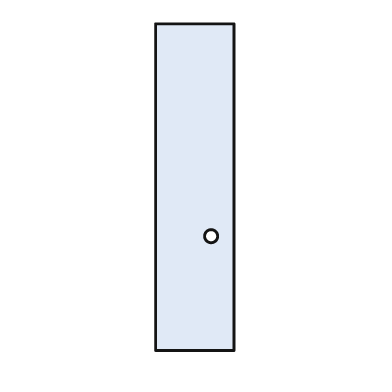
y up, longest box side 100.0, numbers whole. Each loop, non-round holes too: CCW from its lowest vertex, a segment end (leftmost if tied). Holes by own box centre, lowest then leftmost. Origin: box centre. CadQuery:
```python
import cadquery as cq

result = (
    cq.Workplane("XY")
    .moveTo(-12.0, -50.0)
    .lineTo(12.0, -50.0)
    .lineTo(12.0, 50.0)
    .lineTo(-12.0, 50.0)
    .close()
    .moveTo(5.0, -15.0)
    .circle(2.0)
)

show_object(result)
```